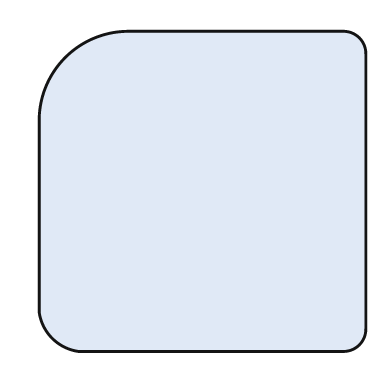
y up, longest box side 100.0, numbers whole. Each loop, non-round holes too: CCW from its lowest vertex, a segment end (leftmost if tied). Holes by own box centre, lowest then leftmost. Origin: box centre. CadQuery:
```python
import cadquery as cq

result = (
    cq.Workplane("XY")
    .moveTo(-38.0, -49.0)
    .lineTo(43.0, -49.0)
    .threePointArc((48.0, -47.0), (50.0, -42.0))
    .lineTo(50.0, 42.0)
    .threePointArc((48.0, 47.0), (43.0, 49.0))
    .lineTo(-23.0, 49.0)
    .threePointArc((-42.0, 41.0), (-50.0, 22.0))
    .lineTo(-50.0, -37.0)
    .threePointArc((-46.0, -45.0), (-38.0, -49.0))
    .close()
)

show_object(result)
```